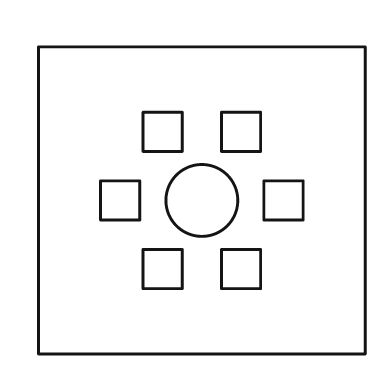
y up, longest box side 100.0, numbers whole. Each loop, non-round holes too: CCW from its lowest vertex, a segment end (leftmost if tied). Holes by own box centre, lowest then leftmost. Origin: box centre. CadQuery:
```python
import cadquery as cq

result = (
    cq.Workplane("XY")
    .moveTo(-50.0, -47.0)
    .lineTo(50.0, -47.0)
    .lineTo(50.0, 47.0)
    .lineTo(-50.0, 47.0)
    .close()
    .moveTo(-18.0, -27.0)
    .lineTo(-6.0, -27.0)
    .lineTo(-6.0, -15.0)
    .lineTo(-18.0, -15.0)
    .close()
    .moveTo(6.0, -27.0)
    .lineTo(18.0, -27.0)
    .lineTo(18.0, -15.0)
    .lineTo(6.0, -15.0)
    .close()
    .moveTo(-31.0, -6.0)
    .lineTo(-19.0, -6.0)
    .lineTo(-19.0, 6.0)
    .lineTo(-31.0, 6.0)
    .close()
    .moveTo(0.0, 0.0)
    .circle(11.0)
    .moveTo(19.0, -6.0)
    .lineTo(31.0, -6.0)
    .lineTo(31.0, 6.0)
    .lineTo(19.0, 6.0)
    .close()
    .moveTo(-18.0, 15.0)
    .lineTo(-6.0, 15.0)
    .lineTo(-6.0, 27.0)
    .lineTo(-18.0, 27.0)
    .close()
    .moveTo(6.0, 15.0)
    .lineTo(18.0, 15.0)
    .lineTo(18.0, 27.0)
    .lineTo(6.0, 27.0)
    .close()
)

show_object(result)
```